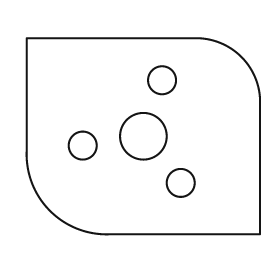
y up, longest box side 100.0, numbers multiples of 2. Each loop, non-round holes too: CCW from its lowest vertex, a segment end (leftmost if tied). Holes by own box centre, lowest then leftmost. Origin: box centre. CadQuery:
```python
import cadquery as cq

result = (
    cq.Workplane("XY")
    .moveTo(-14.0, -42.0)
    .lineTo(50.0, -42.0)
    .lineTo(50.0, 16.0)
    .threePointArc((42.0, 34.0), (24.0, 42.0))
    .lineTo(-50.0, 42.0)
    .lineTo(-50.0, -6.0)
    .threePointArc((-40.0, -32.0), (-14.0, -42.0))
    .close()
    .moveTo(16.0, -20.0)
    .circle(6.0)
    .moveTo(-26.0, -4.0)
    .circle(6.0)
    .moveTo(0.0, 0.0)
    .circle(10.0)
    .moveTo(8.0, 24.0)
    .circle(6.0)
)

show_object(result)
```